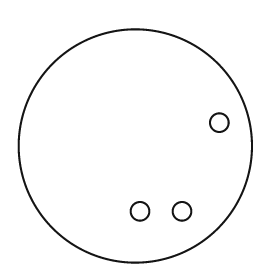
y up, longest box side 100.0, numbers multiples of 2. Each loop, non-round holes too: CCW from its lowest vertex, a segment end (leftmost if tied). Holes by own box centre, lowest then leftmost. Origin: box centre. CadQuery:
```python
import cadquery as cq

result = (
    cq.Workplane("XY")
    .moveTo(0.0, 0.0)
    .circle(50.0)
    .moveTo(2.0, -28.0)
    .circle(4.0)
    .moveTo(20.0, -28.0)
    .circle(4.0)
    .moveTo(36.0, 10.0)
    .circle(4.0)
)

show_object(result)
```